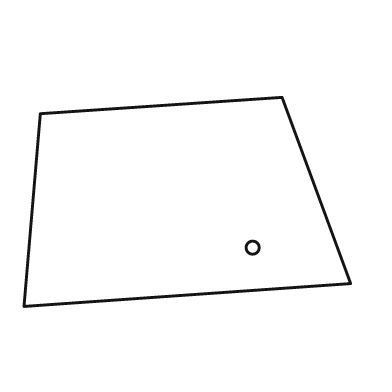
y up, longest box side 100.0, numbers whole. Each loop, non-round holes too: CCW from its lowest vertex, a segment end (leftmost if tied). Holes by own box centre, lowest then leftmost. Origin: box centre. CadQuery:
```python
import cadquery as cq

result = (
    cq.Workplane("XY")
    .moveTo(-50.0, -32.0)
    .lineTo(50.0, -25.0)
    .lineTo(29.0, 32.0)
    .lineTo(-45.0, 27.0)
    .close()
    .moveTo(20.0, -14.0)
    .circle(2.0)
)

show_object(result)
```